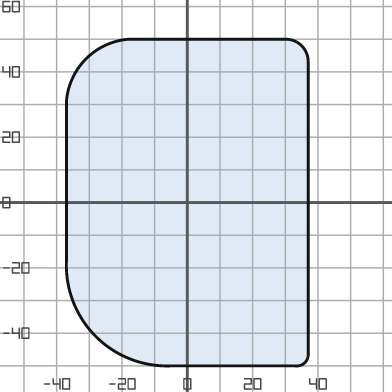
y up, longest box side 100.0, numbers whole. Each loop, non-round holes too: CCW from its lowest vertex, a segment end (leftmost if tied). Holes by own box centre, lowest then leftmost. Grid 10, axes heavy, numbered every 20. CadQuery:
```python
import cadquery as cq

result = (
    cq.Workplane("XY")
    .moveTo(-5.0, -50.0)
    .lineTo(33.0, -50.0)
    .threePointArc((36.0, -49.0), (37.0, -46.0))
    .lineTo(37.0, 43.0)
    .threePointArc((35.0, 48.0), (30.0, 50.0))
    .lineTo(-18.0, 50.0)
    .threePointArc((-31.0, 44.0), (-37.0, 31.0))
    .lineTo(-37.0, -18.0)
    .threePointArc((-28.0, -41.0), (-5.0, -50.0))
    .close()
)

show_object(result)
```